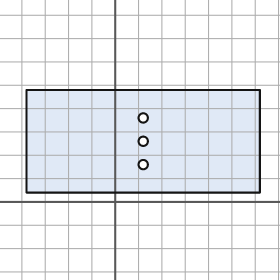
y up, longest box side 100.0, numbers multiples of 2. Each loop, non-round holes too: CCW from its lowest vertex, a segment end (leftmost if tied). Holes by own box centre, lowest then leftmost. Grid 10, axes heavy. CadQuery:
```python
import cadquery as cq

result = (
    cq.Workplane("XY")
    .moveTo(-38.0, 4.0)
    .lineTo(62.0, 4.0)
    .lineTo(62.0, 48.0)
    .lineTo(-38.0, 48.0)
    .close()
    .moveTo(12.0, 16.0)
    .circle(2.0)
    .moveTo(12.0, 26.0)
    .circle(2.0)
    .moveTo(12.0, 36.0)
    .circle(2.0)
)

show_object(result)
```